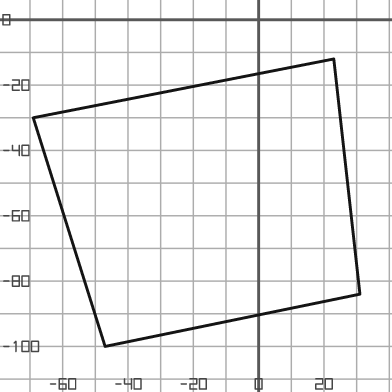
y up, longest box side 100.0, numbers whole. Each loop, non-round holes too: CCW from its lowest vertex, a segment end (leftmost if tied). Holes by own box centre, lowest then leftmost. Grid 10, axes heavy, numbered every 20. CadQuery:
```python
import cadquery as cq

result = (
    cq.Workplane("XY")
    .moveTo(-47.0, -100.0)
    .lineTo(31.0, -84.0)
    .lineTo(23.0, -12.0)
    .lineTo(-69.0, -30.0)
    .close()
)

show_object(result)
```